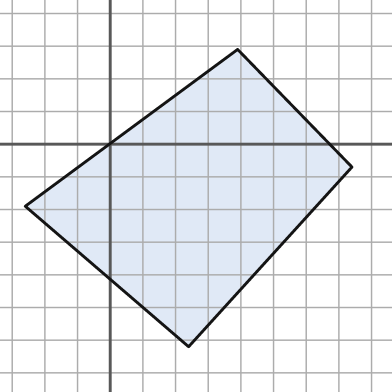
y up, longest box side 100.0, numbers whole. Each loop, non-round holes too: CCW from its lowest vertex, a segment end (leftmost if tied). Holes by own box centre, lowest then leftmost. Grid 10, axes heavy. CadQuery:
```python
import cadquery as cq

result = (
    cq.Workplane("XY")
    .moveTo(24.0, -62.0)
    .lineTo(74.0, -7.0)
    .lineTo(39.0, 29.0)
    .lineTo(-26.0, -19.0)
    .close()
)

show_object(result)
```